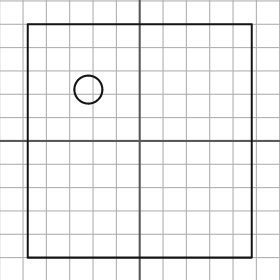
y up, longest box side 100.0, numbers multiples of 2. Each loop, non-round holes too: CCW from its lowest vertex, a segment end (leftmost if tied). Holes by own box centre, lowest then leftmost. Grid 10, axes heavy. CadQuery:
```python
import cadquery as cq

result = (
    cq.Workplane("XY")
    .moveTo(-48.0, -50.0)
    .lineTo(48.0, -50.0)
    .lineTo(48.0, 50.0)
    .lineTo(-48.0, 50.0)
    .close()
    .moveTo(-22.0, 22.0)
    .circle(6.0)
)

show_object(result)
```